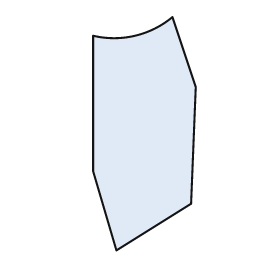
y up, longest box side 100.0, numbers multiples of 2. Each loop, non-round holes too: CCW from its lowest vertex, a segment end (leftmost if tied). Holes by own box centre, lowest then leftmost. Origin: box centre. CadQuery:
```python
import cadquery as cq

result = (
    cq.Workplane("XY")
    .moveTo(-12.0, -50.0)
    .lineTo(20.0, -30.0)
    .lineTo(22.0, 20.0)
    .lineTo(12.0, 50.0)
    .threePointArc((-4.0, 42.0), (-22.0, 42.0))
    .lineTo(-22.0, -16.0)
    .close()
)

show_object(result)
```